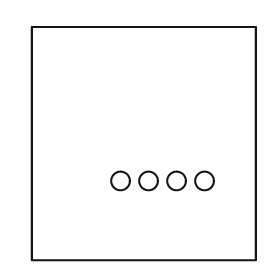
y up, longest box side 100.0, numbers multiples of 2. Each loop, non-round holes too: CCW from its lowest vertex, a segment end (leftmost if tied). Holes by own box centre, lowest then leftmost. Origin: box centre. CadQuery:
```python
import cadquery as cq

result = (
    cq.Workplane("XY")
    .moveTo(-48.0, -50.0)
    .lineTo(48.0, -50.0)
    .lineTo(48.0, 50.0)
    .lineTo(-48.0, 50.0)
    .close()
    .moveTo(-10.0, -16.0)
    .circle(4.0)
    .moveTo(2.0, -16.0)
    .circle(4.0)
    .moveTo(14.0, -16.0)
    .circle(4.0)
    .moveTo(26.0, -16.0)
    .circle(4.0)
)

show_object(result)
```